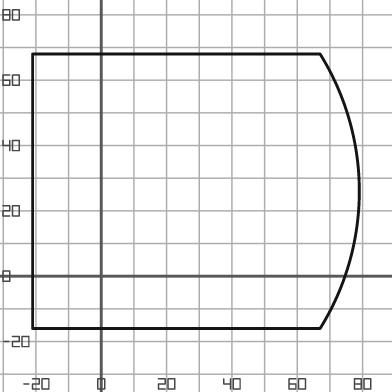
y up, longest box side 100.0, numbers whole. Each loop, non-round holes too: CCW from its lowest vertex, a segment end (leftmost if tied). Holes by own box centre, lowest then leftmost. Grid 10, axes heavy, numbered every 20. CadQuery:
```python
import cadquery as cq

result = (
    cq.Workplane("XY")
    .moveTo(-21.0, -16.0)
    .lineTo(67.0, -16.0)
    .threePointArc((79.0, 26.0), (67.0, 68.0))
    .lineTo(-21.0, 68.0)
    .close()
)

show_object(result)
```